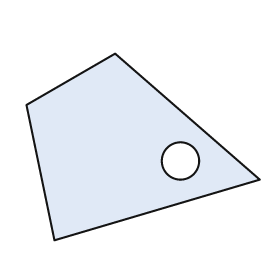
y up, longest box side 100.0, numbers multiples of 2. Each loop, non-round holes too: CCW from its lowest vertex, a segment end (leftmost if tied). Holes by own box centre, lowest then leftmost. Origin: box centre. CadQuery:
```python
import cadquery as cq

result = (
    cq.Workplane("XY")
    .moveTo(-38.0, -40.0)
    .lineTo(50.0, -14.0)
    .lineTo(-12.0, 40.0)
    .lineTo(-50.0, 18.0)
    .close()
    .moveTo(16.0, -6.0)
    .circle(8.0)
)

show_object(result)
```